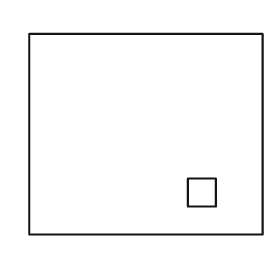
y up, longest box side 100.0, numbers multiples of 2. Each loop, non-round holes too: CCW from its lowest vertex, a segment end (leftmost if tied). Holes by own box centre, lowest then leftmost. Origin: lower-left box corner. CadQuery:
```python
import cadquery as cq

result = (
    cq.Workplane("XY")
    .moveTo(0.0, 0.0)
    .lineTo(100.0, 0.0)
    .lineTo(100.0, 86.0)
    .lineTo(0.0, 86.0)
    .close()
    .moveTo(68.0, 12.0)
    .lineTo(80.0, 12.0)
    .lineTo(80.0, 24.0)
    .lineTo(68.0, 24.0)
    .close()
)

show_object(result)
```